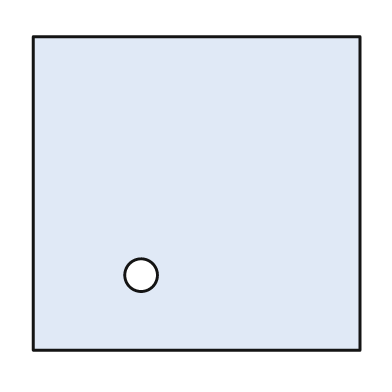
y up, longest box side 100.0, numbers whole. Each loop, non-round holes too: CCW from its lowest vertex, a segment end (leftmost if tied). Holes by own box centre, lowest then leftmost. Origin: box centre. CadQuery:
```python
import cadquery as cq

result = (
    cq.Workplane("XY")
    .moveTo(-50.0, -48.0)
    .lineTo(50.0, -48.0)
    .lineTo(50.0, 48.0)
    .lineTo(-50.0, 48.0)
    .close()
    .moveTo(-17.0, -25.0)
    .circle(5.0)
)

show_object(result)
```